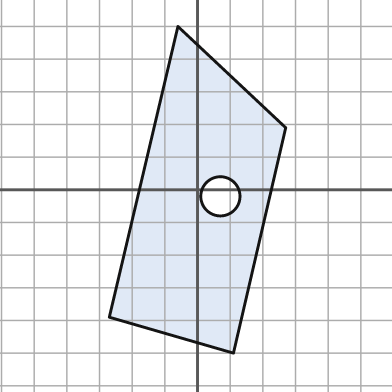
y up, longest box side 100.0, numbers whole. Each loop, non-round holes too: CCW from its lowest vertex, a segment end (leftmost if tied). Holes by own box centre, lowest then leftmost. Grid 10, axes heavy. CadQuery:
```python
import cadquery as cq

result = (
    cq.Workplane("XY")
    .moveTo(11.0, -50.0)
    .lineTo(27.0, 19.0)
    .lineTo(-6.0, 50.0)
    .lineTo(-27.0, -39.0)
    .close()
    .moveTo(7.0, -2.0)
    .circle(6.0)
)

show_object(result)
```